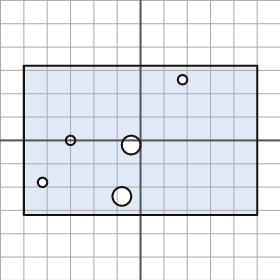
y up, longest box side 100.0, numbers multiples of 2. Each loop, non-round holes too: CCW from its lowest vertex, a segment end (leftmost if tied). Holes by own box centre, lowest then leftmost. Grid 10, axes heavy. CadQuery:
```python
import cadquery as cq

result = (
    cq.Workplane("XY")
    .moveTo(-50.0, -32.0)
    .lineTo(50.0, -32.0)
    .lineTo(50.0, 32.0)
    .lineTo(-50.0, 32.0)
    .close()
    .moveTo(-8.0, -24.0)
    .circle(4.0)
    .moveTo(-42.0, -18.0)
    .circle(2.0)
    .moveTo(-4.0, -2.0)
    .circle(4.0)
    .moveTo(-30.0, 0.0)
    .circle(2.0)
    .moveTo(18.0, 26.0)
    .circle(2.0)
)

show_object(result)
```